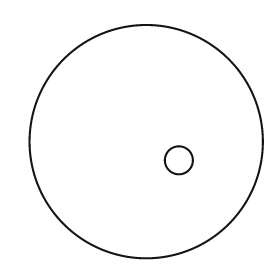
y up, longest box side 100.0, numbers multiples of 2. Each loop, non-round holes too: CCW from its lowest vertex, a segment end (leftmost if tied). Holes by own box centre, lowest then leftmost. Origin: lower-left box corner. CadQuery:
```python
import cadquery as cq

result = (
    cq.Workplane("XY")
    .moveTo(50.0, 50.0)
    .circle(50.0)
    .moveTo(64.0, 42.0)
    .circle(6.0)
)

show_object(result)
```